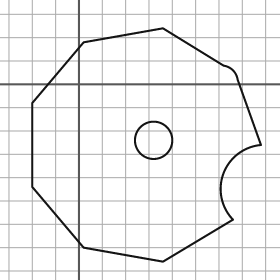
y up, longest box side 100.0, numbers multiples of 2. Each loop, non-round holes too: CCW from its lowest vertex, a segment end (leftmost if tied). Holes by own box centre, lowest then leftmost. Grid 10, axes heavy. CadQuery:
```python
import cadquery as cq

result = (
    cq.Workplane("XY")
    .moveTo(36.0, -76.0)
    .lineTo(66.0, -58.0)
    .threePointArc((62.0, -38.0), (78.0, -26.0))
    .lineTo(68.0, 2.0)
    .threePointArc((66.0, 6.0), (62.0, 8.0))
    .lineTo(36.0, 24.0)
    .lineTo(2.0, 18.0)
    .lineTo(-20.0, -8.0)
    .lineTo(-20.0, -44.0)
    .lineTo(2.0, -70.0)
    .close()
    .moveTo(32.0, -24.0)
    .circle(8.0)
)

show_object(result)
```